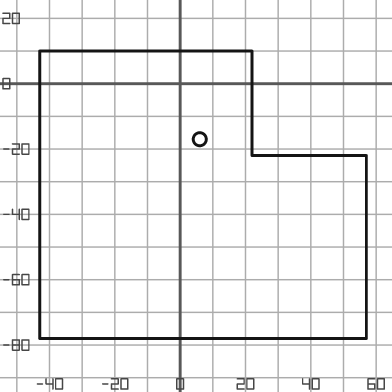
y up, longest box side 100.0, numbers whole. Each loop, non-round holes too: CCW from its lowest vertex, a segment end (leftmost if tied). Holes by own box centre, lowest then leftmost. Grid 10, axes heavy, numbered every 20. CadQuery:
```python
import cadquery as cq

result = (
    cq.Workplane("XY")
    .moveTo(-43.0, -78.0)
    .lineTo(57.0, -78.0)
    .lineTo(57.0, -22.0)
    .lineTo(22.0, -22.0)
    .lineTo(22.0, 10.0)
    .lineTo(-43.0, 10.0)
    .close()
    .moveTo(6.0, -17.0)
    .circle(2.0)
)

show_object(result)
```